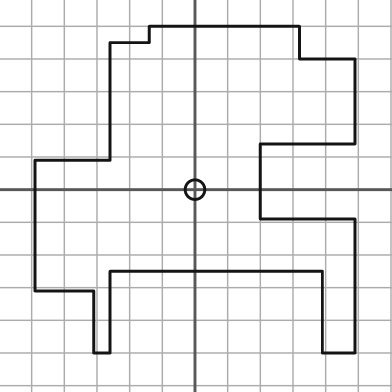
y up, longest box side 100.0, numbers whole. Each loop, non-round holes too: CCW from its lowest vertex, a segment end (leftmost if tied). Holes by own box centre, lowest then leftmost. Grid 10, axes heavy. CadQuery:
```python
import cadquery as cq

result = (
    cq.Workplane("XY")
    .moveTo(-31.0, -50.0)
    .lineTo(-26.0, -50.0)
    .lineTo(-26.0, -25.0)
    .lineTo(39.0, -25.0)
    .lineTo(39.0, -50.0)
    .lineTo(49.0, -50.0)
    .lineTo(49.0, -9.0)
    .lineTo(20.0, -9.0)
    .lineTo(20.0, 14.0)
    .lineTo(49.0, 14.0)
    .lineTo(49.0, 40.0)
    .lineTo(32.0, 40.0)
    .lineTo(32.0, 50.0)
    .lineTo(-14.0, 50.0)
    .lineTo(-14.0, 45.0)
    .lineTo(-26.0, 45.0)
    .lineTo(-26.0, 9.0)
    .lineTo(-49.0, 9.0)
    .lineTo(-49.0, -31.0)
    .lineTo(-31.0, -31.0)
    .close()
    .moveTo(0.0, 0.0)
    .circle(3.0)
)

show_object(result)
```